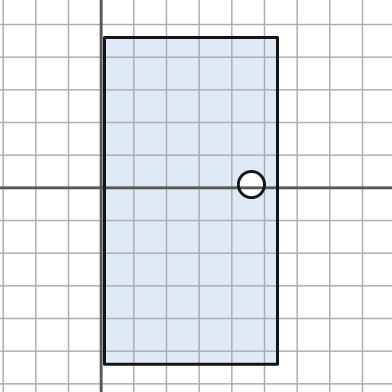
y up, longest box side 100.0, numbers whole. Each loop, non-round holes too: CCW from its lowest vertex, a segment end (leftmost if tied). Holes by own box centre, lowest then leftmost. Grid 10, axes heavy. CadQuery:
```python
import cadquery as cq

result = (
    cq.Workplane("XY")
    .moveTo(1.0, -54.0)
    .lineTo(54.0, -54.0)
    .lineTo(54.0, 46.0)
    .lineTo(1.0, 46.0)
    .close()
    .moveTo(46.0, 1.0)
    .circle(4.0)
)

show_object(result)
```